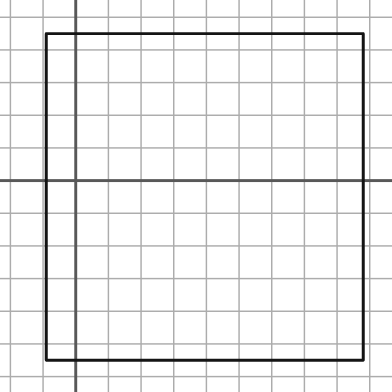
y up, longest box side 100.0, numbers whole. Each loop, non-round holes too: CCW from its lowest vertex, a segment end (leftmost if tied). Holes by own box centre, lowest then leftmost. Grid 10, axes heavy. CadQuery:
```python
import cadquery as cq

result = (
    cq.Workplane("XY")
    .moveTo(-9.0, -55.0)
    .lineTo(88.0, -55.0)
    .lineTo(88.0, 45.0)
    .lineTo(-9.0, 45.0)
    .close()
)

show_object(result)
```